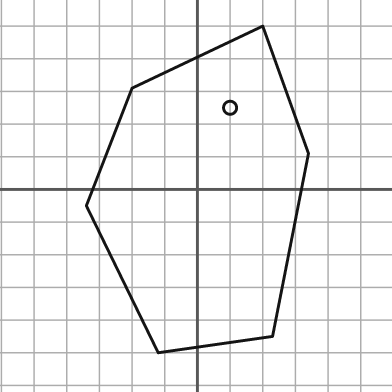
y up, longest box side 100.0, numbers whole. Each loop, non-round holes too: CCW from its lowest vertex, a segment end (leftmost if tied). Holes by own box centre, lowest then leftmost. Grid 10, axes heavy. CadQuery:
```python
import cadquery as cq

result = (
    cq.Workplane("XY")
    .moveTo(-12.0, -50.0)
    .lineTo(23.0, -45.0)
    .lineTo(34.0, 11.0)
    .lineTo(20.0, 50.0)
    .lineTo(-20.0, 31.0)
    .lineTo(-34.0, -5.0)
    .close()
    .moveTo(10.0, 25.0)
    .circle(2.0)
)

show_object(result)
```